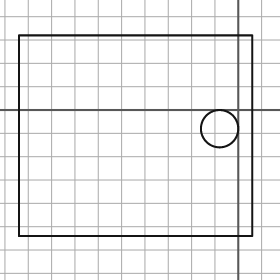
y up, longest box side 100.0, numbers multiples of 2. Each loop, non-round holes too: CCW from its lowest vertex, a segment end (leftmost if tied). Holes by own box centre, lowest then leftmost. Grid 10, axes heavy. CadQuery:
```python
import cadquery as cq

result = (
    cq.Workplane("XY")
    .moveTo(-94.0, -54.0)
    .lineTo(6.0, -54.0)
    .lineTo(6.0, 32.0)
    .lineTo(-94.0, 32.0)
    .close()
    .moveTo(-8.0, -8.0)
    .circle(8.0)
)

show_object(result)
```